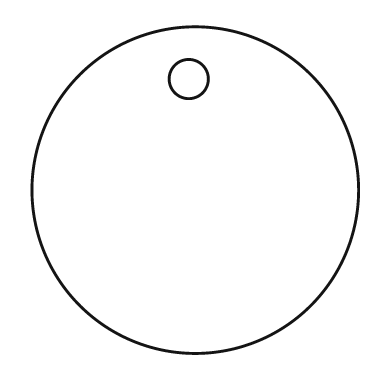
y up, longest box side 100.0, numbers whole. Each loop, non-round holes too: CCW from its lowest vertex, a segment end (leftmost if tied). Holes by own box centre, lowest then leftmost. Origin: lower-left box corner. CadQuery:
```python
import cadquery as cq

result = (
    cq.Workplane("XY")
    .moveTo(50.0, 50.0)
    .circle(50.0)
    .moveTo(48.0, 84.0)
    .circle(6.0)
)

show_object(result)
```